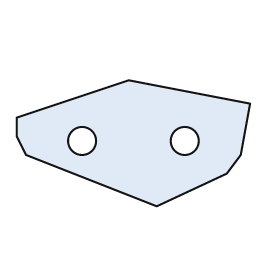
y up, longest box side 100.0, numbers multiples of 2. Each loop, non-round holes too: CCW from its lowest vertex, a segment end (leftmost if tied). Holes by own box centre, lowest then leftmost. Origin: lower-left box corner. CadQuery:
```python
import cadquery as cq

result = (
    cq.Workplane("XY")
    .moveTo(60.0, 0.0)
    .lineTo(90.0, 14.0)
    .lineTo(96.0, 22.0)
    .lineTo(100.0, 44.0)
    .lineTo(48.0, 54.0)
    .lineTo(0.0, 38.0)
    .lineTo(0.0, 30.0)
    .lineTo(4.0, 22.0)
    .close()
    .moveTo(28.0, 28.0)
    .circle(6.0)
    .moveTo(72.0, 28.0)
    .circle(6.0)
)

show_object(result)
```